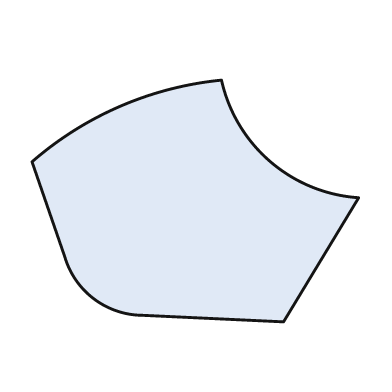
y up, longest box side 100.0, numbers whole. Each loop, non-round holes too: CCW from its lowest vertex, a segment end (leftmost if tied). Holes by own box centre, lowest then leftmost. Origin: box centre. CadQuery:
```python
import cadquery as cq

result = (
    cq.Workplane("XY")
    .moveTo(27.0, -37.0)
    .lineTo(50.0, 1.0)
    .threePointArc((23.0, 12.0), (8.0, 37.0))
    .threePointArc((-23.0, 29.0), (-50.0, 12.0))
    .lineTo(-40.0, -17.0)
    .threePointArc((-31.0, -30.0), (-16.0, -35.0))
    .close()
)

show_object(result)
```